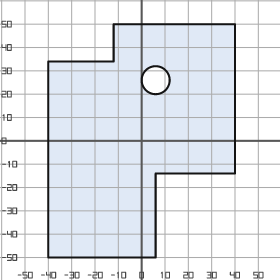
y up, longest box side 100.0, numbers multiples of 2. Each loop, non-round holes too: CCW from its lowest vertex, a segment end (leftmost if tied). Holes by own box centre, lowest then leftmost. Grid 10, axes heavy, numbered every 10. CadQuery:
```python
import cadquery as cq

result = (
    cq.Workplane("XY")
    .moveTo(-40.0, -50.0)
    .lineTo(6.0, -50.0)
    .lineTo(6.0, -14.0)
    .lineTo(40.0, -14.0)
    .lineTo(40.0, 50.0)
    .lineTo(-12.0, 50.0)
    .lineTo(-12.0, 34.0)
    .lineTo(-40.0, 34.0)
    .close()
    .moveTo(6.0, 26.0)
    .circle(6.0)
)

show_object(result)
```